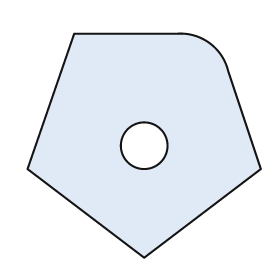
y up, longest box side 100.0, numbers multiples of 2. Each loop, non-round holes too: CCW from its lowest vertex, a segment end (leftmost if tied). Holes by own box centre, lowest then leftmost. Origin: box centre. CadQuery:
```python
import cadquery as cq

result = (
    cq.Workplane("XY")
    .moveTo(0.0, -48.0)
    .lineTo(50.0, -10.0)
    .lineTo(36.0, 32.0)
    .threePointArc((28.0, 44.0), (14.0, 48.0))
    .lineTo(-30.0, 48.0)
    .lineTo(-50.0, -10.0)
    .close()
    .moveTo(0.0, 0.0)
    .circle(10.0)
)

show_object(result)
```